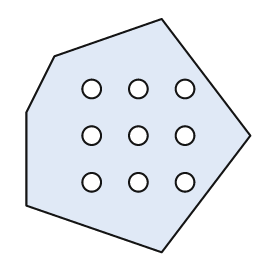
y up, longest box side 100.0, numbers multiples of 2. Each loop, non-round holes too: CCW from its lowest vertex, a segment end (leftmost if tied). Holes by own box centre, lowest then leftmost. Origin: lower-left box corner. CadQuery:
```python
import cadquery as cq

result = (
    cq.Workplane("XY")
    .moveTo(58.0, 0.0)
    .lineTo(96.0, 50.0)
    .lineTo(58.0, 100.0)
    .lineTo(12.0, 84.0)
    .lineTo(0.0, 60.0)
    .lineTo(0.0, 20.0)
    .close()
    .moveTo(28.0, 30.0)
    .circle(4.0)
    .moveTo(48.0, 30.0)
    .circle(4.0)
    .moveTo(68.0, 30.0)
    .circle(4.0)
    .moveTo(28.0, 50.0)
    .circle(4.0)
    .moveTo(48.0, 50.0)
    .circle(4.0)
    .moveTo(68.0, 50.0)
    .circle(4.0)
    .moveTo(28.0, 70.0)
    .circle(4.0)
    .moveTo(48.0, 70.0)
    .circle(4.0)
    .moveTo(68.0, 70.0)
    .circle(4.0)
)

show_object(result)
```